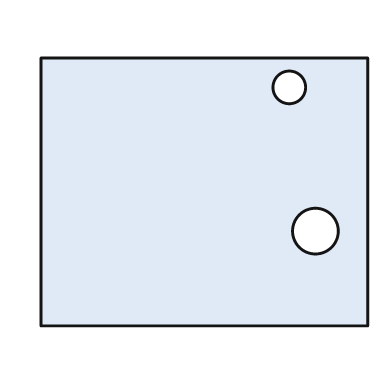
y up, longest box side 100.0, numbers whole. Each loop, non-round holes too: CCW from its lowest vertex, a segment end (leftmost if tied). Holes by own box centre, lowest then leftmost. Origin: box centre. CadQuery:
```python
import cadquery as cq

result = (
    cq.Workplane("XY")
    .moveTo(-50.0, -41.0)
    .lineTo(50.0, -41.0)
    .lineTo(50.0, 41.0)
    .lineTo(-50.0, 41.0)
    .close()
    .moveTo(34.0, -12.0)
    .circle(7.0)
    .moveTo(26.0, 32.0)
    .circle(5.0)
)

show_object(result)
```